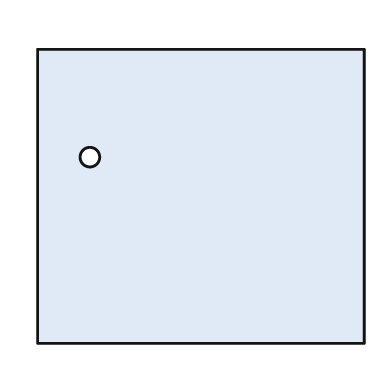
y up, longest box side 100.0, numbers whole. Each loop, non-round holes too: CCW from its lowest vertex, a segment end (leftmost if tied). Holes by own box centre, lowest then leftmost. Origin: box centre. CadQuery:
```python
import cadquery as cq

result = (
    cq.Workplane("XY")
    .moveTo(-50.0, -45.0)
    .lineTo(50.0, -45.0)
    .lineTo(50.0, 45.0)
    .lineTo(-50.0, 45.0)
    .close()
    .moveTo(-34.0, 12.0)
    .circle(3.0)
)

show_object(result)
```